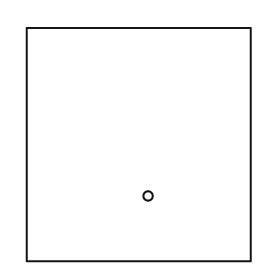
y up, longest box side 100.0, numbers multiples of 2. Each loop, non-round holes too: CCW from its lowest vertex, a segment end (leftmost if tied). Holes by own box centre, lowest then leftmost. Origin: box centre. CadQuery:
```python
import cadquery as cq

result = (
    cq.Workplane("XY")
    .moveTo(-48.0, -50.0)
    .lineTo(48.0, -50.0)
    .lineTo(48.0, 50.0)
    .lineTo(-48.0, 50.0)
    .close()
    .moveTo(4.0, -22.0)
    .circle(2.0)
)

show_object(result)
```